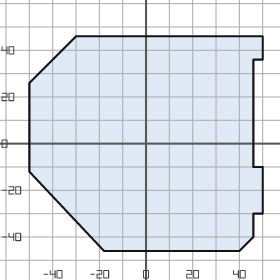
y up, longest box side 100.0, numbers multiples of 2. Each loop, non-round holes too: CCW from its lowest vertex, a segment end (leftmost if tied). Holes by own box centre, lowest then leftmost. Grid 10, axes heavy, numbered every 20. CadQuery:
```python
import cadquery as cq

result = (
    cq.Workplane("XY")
    .moveTo(-18.0, -46.0)
    .lineTo(40.0, -46.0)
    .lineTo(46.0, -40.0)
    .lineTo(46.0, -30.0)
    .lineTo(50.0, -30.0)
    .lineTo(50.0, -10.0)
    .lineTo(46.0, -10.0)
    .lineTo(46.0, 36.0)
    .lineTo(50.0, 36.0)
    .lineTo(50.0, 46.0)
    .lineTo(-30.0, 46.0)
    .lineTo(-50.0, 26.0)
    .lineTo(-50.0, -12.0)
    .close()
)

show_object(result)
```